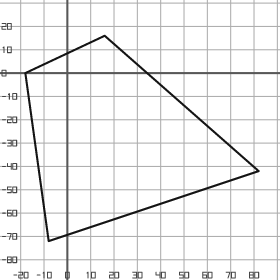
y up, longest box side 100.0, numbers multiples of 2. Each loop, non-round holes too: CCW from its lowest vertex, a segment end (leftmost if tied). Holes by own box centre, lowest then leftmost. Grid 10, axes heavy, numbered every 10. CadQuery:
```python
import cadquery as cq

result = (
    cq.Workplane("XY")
    .moveTo(-8.0, -72.0)
    .lineTo(82.0, -42.0)
    .lineTo(16.0, 16.0)
    .lineTo(-18.0, 0.0)
    .close()
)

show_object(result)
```